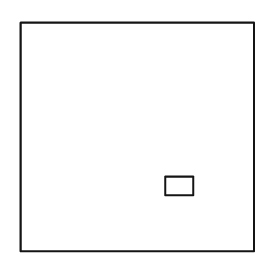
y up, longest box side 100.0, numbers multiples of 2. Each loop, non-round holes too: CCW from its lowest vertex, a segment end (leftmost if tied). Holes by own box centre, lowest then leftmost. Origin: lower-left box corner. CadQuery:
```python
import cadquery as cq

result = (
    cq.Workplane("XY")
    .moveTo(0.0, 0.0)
    .lineTo(100.0, 0.0)
    .lineTo(100.0, 98.0)
    .lineTo(0.0, 98.0)
    .close()
    .moveTo(62.0, 24.0)
    .lineTo(74.0, 24.0)
    .lineTo(74.0, 32.0)
    .lineTo(62.0, 32.0)
    .close()
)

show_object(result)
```